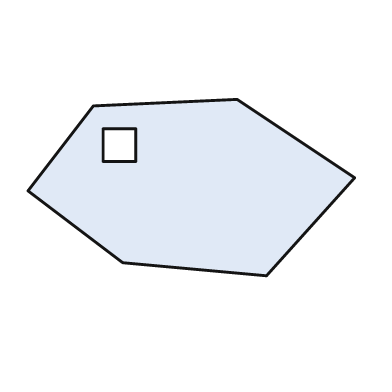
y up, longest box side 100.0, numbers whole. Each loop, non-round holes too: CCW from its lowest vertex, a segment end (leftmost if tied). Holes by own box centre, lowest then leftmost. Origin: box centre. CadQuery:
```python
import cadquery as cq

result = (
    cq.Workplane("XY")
    .moveTo(23.0, -27.0)
    .lineTo(50.0, 3.0)
    .lineTo(14.0, 27.0)
    .lineTo(-30.0, 25.0)
    .lineTo(-50.0, -1.0)
    .lineTo(-21.0, -23.0)
    .close()
    .moveTo(-27.0, 8.0)
    .lineTo(-17.0, 8.0)
    .lineTo(-17.0, 18.0)
    .lineTo(-27.0, 18.0)
    .close()
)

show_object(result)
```